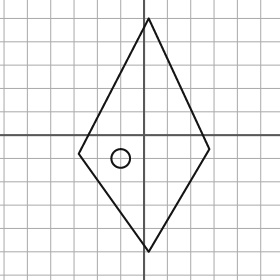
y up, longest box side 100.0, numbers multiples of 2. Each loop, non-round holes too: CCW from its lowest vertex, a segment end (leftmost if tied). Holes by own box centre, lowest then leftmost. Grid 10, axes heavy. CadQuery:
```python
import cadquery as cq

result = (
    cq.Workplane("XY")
    .moveTo(2.0, -50.0)
    .lineTo(28.0, -6.0)
    .lineTo(2.0, 50.0)
    .lineTo(-28.0, -8.0)
    .close()
    .moveTo(-10.0, -10.0)
    .circle(4.0)
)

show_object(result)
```